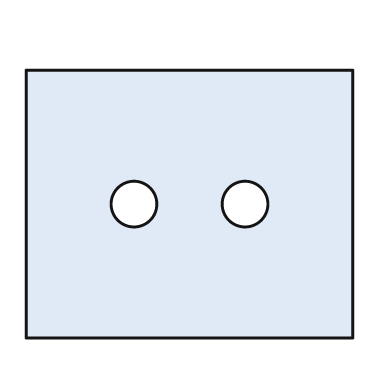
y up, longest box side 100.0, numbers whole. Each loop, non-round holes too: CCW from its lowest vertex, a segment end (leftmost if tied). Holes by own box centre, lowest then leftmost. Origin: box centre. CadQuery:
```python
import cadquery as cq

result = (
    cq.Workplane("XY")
    .moveTo(-50.0, -41.0)
    .lineTo(50.0, -41.0)
    .lineTo(50.0, 41.0)
    .lineTo(-50.0, 41.0)
    .close()
    .moveTo(-17.0, 0.0)
    .circle(7.0)
    .moveTo(17.0, 0.0)
    .circle(7.0)
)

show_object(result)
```